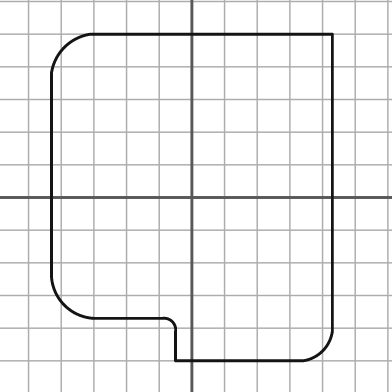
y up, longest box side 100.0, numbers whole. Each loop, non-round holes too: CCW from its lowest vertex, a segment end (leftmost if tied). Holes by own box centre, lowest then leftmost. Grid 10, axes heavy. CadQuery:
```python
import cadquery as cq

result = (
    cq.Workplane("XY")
    .moveTo(-5.0, -50.0)
    .lineTo(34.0, -50.0)
    .threePointArc((40.0, -47.0), (43.0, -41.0))
    .lineTo(43.0, 50.0)
    .lineTo(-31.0, 50.0)
    .threePointArc((-39.0, 46.0), (-43.0, 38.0))
    .lineTo(-43.0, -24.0)
    .threePointArc((-39.0, -33.0), (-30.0, -37.0))
    .lineTo(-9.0, -37.0)
    .threePointArc((-6.0, -38.0), (-5.0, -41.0))
    .close()
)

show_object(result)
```